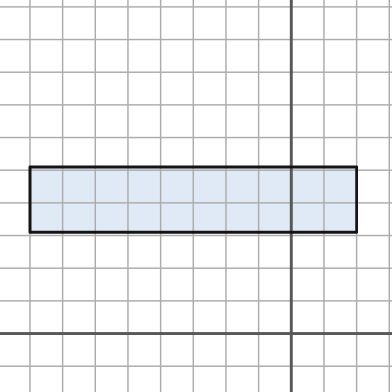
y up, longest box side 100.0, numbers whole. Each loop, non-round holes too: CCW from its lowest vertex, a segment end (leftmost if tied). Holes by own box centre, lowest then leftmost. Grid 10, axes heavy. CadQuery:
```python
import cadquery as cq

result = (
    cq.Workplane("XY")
    .moveTo(-80.0, 31.0)
    .lineTo(20.0, 31.0)
    .lineTo(20.0, 51.0)
    .lineTo(-80.0, 51.0)
    .close()
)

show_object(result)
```